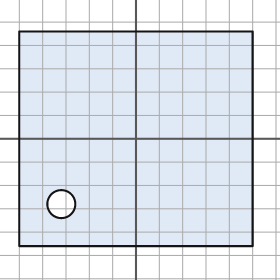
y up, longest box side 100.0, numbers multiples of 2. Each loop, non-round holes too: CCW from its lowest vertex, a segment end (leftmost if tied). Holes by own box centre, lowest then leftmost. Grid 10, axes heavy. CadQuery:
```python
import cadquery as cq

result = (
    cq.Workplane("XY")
    .moveTo(-50.0, -46.0)
    .lineTo(50.0, -46.0)
    .lineTo(50.0, 46.0)
    .lineTo(-50.0, 46.0)
    .close()
    .moveTo(-32.0, -28.0)
    .circle(6.0)
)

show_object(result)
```